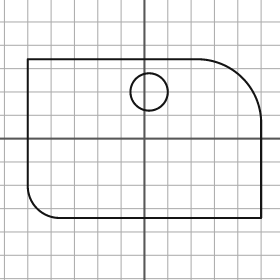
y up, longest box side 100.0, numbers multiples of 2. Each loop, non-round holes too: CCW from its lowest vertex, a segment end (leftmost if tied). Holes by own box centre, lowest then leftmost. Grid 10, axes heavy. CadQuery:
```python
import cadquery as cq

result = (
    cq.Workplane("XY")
    .moveTo(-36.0, -34.0)
    .lineTo(50.0, -34.0)
    .lineTo(50.0, 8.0)
    .threePointArc((42.0, 26.0), (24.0, 34.0))
    .lineTo(-50.0, 34.0)
    .lineTo(-50.0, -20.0)
    .threePointArc((-46.0, -30.0), (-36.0, -34.0))
    .close()
    .moveTo(2.0, 20.0)
    .circle(8.0)
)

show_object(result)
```